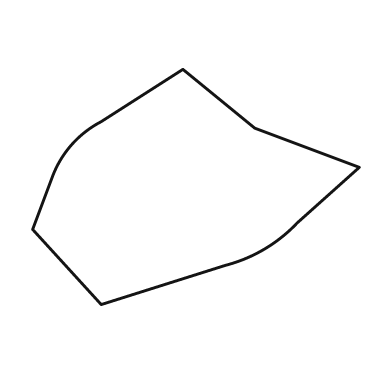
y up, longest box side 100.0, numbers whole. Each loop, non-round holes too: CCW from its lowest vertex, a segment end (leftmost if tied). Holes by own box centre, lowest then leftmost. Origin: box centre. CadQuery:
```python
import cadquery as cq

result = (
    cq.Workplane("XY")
    .moveTo(-29.0, -36.0)
    .lineTo(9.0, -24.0)
    .threePointArc((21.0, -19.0), (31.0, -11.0))
    .lineTo(50.0, 6.0)
    .lineTo(18.0, 18.0)
    .lineTo(-4.0, 36.0)
    .lineTo(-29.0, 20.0)
    .threePointArc((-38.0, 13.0), (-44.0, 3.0))
    .lineTo(-50.0, -13.0)
    .close()
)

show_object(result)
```